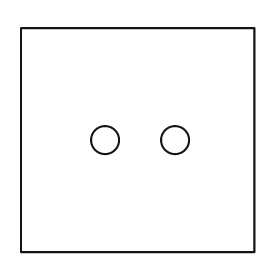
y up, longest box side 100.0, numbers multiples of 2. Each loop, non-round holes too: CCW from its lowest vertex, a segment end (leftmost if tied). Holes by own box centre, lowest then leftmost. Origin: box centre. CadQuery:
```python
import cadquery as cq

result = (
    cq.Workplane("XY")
    .moveTo(-50.0, -48.0)
    .lineTo(50.0, -48.0)
    .lineTo(50.0, 48.0)
    .lineTo(-50.0, 48.0)
    .close()
    .moveTo(-14.0, 0.0)
    .circle(6.0)
    .moveTo(16.0, 0.0)
    .circle(6.0)
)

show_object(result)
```